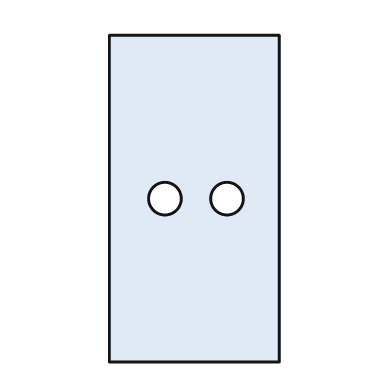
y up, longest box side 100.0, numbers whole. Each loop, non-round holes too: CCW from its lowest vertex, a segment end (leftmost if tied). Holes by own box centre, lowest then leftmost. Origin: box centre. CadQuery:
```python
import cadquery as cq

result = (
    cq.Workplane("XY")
    .moveTo(-26.0, -50.0)
    .lineTo(26.0, -50.0)
    .lineTo(26.0, 50.0)
    .lineTo(-26.0, 50.0)
    .close()
    .moveTo(-9.0, 0.0)
    .circle(5.0)
    .moveTo(10.0, 0.0)
    .circle(5.0)
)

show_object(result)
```